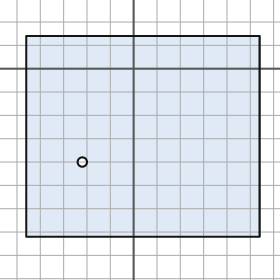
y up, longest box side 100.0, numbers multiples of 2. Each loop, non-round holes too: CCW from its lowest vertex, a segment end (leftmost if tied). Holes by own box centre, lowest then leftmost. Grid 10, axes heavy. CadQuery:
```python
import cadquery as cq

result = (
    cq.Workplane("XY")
    .moveTo(-46.0, -72.0)
    .lineTo(54.0, -72.0)
    .lineTo(54.0, 14.0)
    .lineTo(-46.0, 14.0)
    .close()
    .moveTo(-22.0, -40.0)
    .circle(2.0)
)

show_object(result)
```